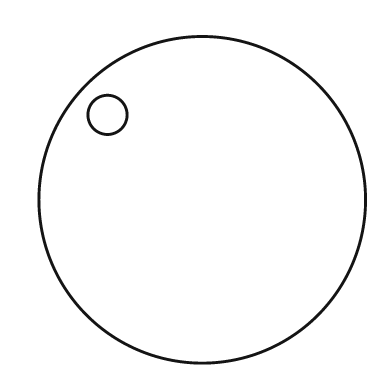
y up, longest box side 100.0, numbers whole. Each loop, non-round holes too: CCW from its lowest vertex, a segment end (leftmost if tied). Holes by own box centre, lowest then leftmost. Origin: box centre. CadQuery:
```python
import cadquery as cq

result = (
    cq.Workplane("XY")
    .moveTo(0.0, 0.0)
    .circle(50.0)
    .moveTo(-29.0, 26.0)
    .circle(6.0)
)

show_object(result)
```